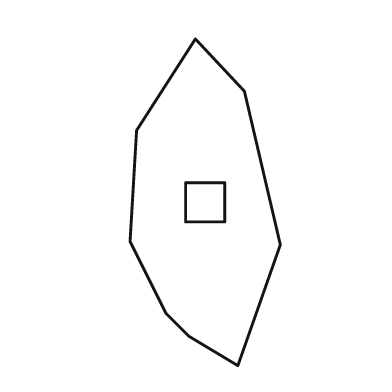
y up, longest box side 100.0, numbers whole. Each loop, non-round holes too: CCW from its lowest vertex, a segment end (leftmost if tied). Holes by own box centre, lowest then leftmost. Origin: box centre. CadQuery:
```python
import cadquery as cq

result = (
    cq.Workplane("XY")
    .moveTo(10.0, -50.0)
    .lineTo(23.0, -13.0)
    .lineTo(12.0, 34.0)
    .lineTo(-3.0, 50.0)
    .lineTo(-21.0, 22.0)
    .lineTo(-23.0, -12.0)
    .lineTo(-12.0, -34.0)
    .lineTo(-5.0, -41.0)
    .close()
    .moveTo(-6.0, -6.0)
    .lineTo(6.0, -6.0)
    .lineTo(6.0, 6.0)
    .lineTo(-6.0, 6.0)
    .close()
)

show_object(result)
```